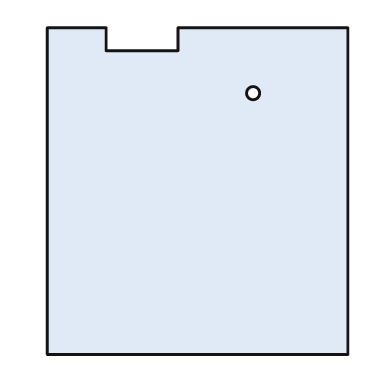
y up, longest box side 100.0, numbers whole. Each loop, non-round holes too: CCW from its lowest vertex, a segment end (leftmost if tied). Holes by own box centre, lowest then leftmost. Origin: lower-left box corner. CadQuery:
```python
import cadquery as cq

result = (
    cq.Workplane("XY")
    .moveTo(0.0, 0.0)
    .lineTo(92.0, 0.0)
    .lineTo(92.0, 100.0)
    .lineTo(40.0, 100.0)
    .lineTo(40.0, 93.0)
    .lineTo(18.0, 93.0)
    .lineTo(18.0, 100.0)
    .lineTo(0.0, 100.0)
    .close()
    .moveTo(63.0, 80.0)
    .circle(2.0)
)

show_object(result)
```